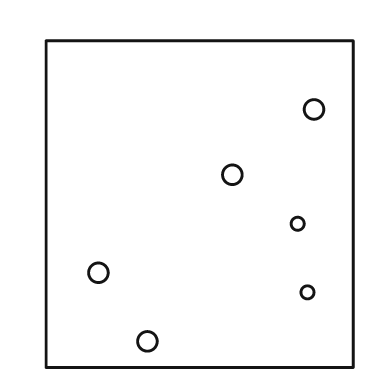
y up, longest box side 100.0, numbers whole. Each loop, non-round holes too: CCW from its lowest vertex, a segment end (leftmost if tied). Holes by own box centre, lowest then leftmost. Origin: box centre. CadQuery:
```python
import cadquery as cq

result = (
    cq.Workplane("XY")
    .moveTo(-47.0, -50.0)
    .lineTo(47.0, -50.0)
    .lineTo(47.0, 50.0)
    .lineTo(-47.0, 50.0)
    .close()
    .moveTo(-16.0, -42.0)
    .circle(3.0)
    .moveTo(33.0, -27.0)
    .circle(2.0)
    .moveTo(-31.0, -21.0)
    .circle(3.0)
    .moveTo(30.0, -6.0)
    .circle(2.0)
    .moveTo(10.0, 9.0)
    .circle(3.0)
    .moveTo(35.0, 29.0)
    .circle(3.0)
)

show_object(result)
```